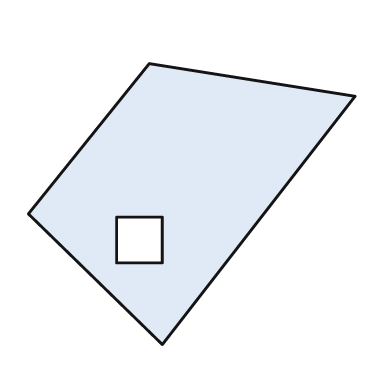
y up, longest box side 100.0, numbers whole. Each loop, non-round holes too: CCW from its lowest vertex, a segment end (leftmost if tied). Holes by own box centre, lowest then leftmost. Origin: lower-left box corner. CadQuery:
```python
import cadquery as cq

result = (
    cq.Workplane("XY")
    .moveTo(41.0, 0.0)
    .lineTo(100.0, 76.0)
    .lineTo(37.0, 86.0)
    .lineTo(0.0, 40.0)
    .close()
    .moveTo(27.0, 25.0)
    .lineTo(41.0, 25.0)
    .lineTo(41.0, 39.0)
    .lineTo(27.0, 39.0)
    .close()
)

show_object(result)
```